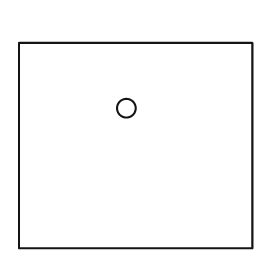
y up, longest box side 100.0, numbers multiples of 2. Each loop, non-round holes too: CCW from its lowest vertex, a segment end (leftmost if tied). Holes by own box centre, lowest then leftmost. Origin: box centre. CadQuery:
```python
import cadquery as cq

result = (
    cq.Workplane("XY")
    .moveTo(-50.0, -44.0)
    .lineTo(50.0, -44.0)
    .lineTo(50.0, 44.0)
    .lineTo(-50.0, 44.0)
    .close()
    .moveTo(-4.0, 16.0)
    .circle(4.0)
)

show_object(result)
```